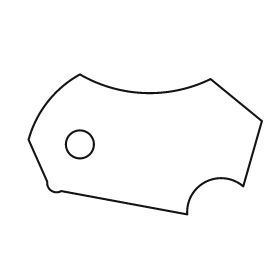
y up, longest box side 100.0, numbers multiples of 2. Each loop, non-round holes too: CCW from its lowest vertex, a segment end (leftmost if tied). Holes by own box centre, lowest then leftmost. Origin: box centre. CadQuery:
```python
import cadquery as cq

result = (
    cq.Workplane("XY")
    .moveTo(18.0, -30.0)
    .threePointArc((26.0, -16.0), (42.0, -18.0))
    .lineTo(50.0, 10.0)
    .lineTo(28.0, 28.0)
    .threePointArc((0.0, 22.0), (-28.0, 30.0))
    .threePointArc((-42.0, 18.0), (-50.0, 2.0))
    .lineTo(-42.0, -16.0)
    .threePointArc((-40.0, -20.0), (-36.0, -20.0))
    .close()
    .moveTo(-28.0, 0.0)
    .circle(6.0)
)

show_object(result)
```